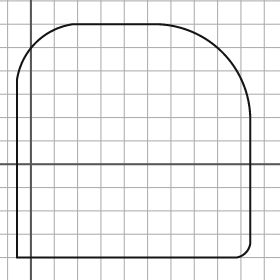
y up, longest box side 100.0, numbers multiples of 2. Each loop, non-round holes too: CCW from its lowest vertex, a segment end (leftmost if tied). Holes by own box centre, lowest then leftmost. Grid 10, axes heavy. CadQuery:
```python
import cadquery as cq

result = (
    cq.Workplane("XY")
    .moveTo(-6.0, -40.0)
    .lineTo(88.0, -40.0)
    .threePointArc((92.0, -38.0), (94.0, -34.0))
    .lineTo(94.0, 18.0)
    .threePointArc((82.0, 48.0), (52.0, 60.0))
    .lineTo(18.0, 60.0)
    .threePointArc((2.0, 52.0), (-6.0, 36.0))
    .close()
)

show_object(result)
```